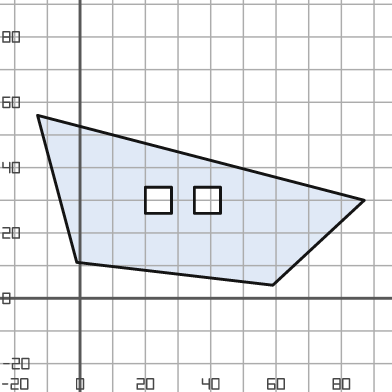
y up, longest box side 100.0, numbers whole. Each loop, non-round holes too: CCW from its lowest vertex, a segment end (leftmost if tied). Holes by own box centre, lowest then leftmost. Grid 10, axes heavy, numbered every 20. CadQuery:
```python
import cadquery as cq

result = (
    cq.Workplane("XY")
    .moveTo(59.0, 4.0)
    .lineTo(87.0, 30.0)
    .lineTo(-13.0, 56.0)
    .lineTo(-1.0, 11.0)
    .close()
    .moveTo(20.0, 26.0)
    .lineTo(28.0, 26.0)
    .lineTo(28.0, 34.0)
    .lineTo(20.0, 34.0)
    .close()
    .moveTo(35.0, 26.0)
    .lineTo(43.0, 26.0)
    .lineTo(43.0, 34.0)
    .lineTo(35.0, 34.0)
    .close()
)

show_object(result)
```